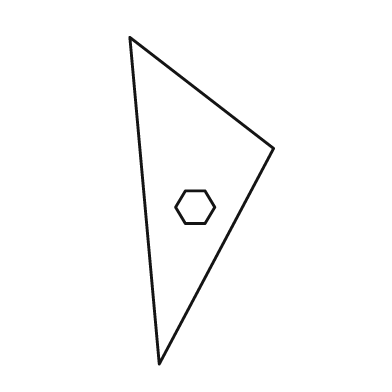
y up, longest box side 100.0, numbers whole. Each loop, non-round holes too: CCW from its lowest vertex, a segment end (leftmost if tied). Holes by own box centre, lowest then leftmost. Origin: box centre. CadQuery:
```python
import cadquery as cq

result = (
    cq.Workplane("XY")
    .moveTo(-13.0, -50.0)
    .lineTo(22.0, 16.0)
    .lineTo(-22.0, 50.0)
    .close()
    .moveTo(-5.0, -7.0)
    .lineTo(1.0, -7.0)
    .lineTo(4.0, -2.0)
    .lineTo(1.0, 3.0)
    .lineTo(-5.0, 3.0)
    .lineTo(-8.0, -2.0)
    .close()
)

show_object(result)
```